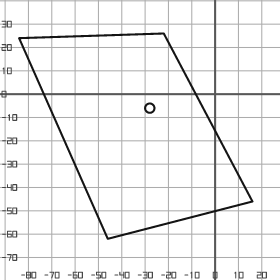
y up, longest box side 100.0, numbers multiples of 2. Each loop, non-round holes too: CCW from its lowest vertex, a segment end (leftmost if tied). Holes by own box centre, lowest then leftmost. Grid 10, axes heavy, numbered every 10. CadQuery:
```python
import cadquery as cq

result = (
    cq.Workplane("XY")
    .moveTo(-46.0, -62.0)
    .lineTo(16.0, -46.0)
    .lineTo(-22.0, 26.0)
    .lineTo(-84.0, 24.0)
    .close()
    .moveTo(-28.0, -6.0)
    .circle(2.0)
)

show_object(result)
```